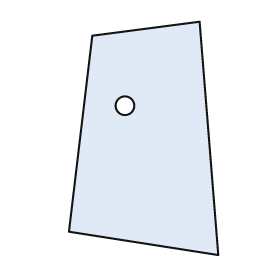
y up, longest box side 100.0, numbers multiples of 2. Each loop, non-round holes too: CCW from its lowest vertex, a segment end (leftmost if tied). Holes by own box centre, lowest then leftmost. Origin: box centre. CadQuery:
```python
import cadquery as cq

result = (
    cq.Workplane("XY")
    .moveTo(32.0, -50.0)
    .lineTo(24.0, 50.0)
    .lineTo(-22.0, 44.0)
    .lineTo(-32.0, -40.0)
    .close()
    .moveTo(-8.0, 14.0)
    .circle(4.0)
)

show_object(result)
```